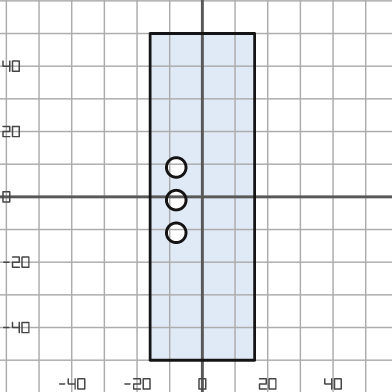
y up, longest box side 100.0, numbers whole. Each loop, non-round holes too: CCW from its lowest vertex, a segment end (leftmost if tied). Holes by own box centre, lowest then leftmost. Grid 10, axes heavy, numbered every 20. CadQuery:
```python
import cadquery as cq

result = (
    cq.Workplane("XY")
    .moveTo(-16.0, -50.0)
    .lineTo(16.0, -50.0)
    .lineTo(16.0, 50.0)
    .lineTo(-16.0, 50.0)
    .close()
    .moveTo(-8.0, -11.0)
    .circle(3.0)
    .moveTo(-8.0, -1.0)
    .circle(3.0)
    .moveTo(-8.0, 9.0)
    .circle(3.0)
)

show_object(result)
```